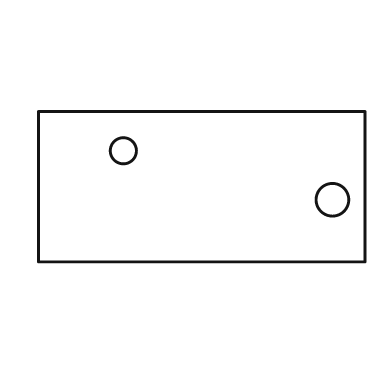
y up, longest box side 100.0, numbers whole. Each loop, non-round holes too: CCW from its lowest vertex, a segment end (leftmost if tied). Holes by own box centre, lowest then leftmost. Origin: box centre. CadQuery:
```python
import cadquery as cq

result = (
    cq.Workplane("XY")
    .moveTo(-50.0, -23.0)
    .lineTo(50.0, -23.0)
    .lineTo(50.0, 23.0)
    .lineTo(-50.0, 23.0)
    .close()
    .moveTo(40.0, -4.0)
    .circle(5.0)
    .moveTo(-24.0, 11.0)
    .circle(4.0)
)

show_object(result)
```